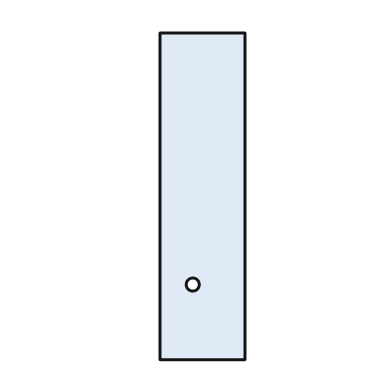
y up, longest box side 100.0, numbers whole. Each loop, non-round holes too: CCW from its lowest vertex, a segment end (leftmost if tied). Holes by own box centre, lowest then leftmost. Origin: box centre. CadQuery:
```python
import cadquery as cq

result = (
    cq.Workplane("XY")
    .moveTo(-13.0, -50.0)
    .lineTo(13.0, -50.0)
    .lineTo(13.0, 50.0)
    .lineTo(-13.0, 50.0)
    .close()
    .moveTo(-3.0, -27.0)
    .circle(2.0)
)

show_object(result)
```